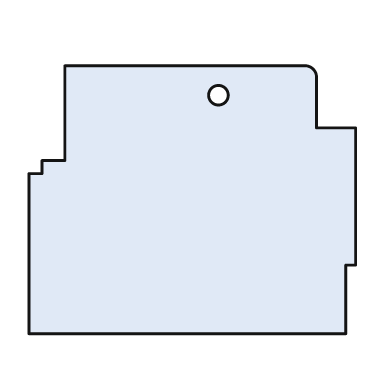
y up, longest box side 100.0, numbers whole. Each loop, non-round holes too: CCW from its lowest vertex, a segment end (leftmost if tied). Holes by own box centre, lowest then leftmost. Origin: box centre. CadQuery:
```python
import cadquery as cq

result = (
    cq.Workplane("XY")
    .moveTo(-50.0, -41.0)
    .lineTo(47.0, -41.0)
    .lineTo(47.0, -20.0)
    .lineTo(50.0, -20.0)
    .lineTo(50.0, 22.0)
    .lineTo(38.0, 22.0)
    .lineTo(38.0, 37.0)
    .threePointArc((37.0, 40.0), (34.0, 41.0))
    .lineTo(-39.0, 41.0)
    .lineTo(-39.0, 12.0)
    .lineTo(-46.0, 12.0)
    .lineTo(-46.0, 8.0)
    .lineTo(-50.0, 8.0)
    .close()
    .moveTo(8.0, 32.0)
    .circle(3.0)
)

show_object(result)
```